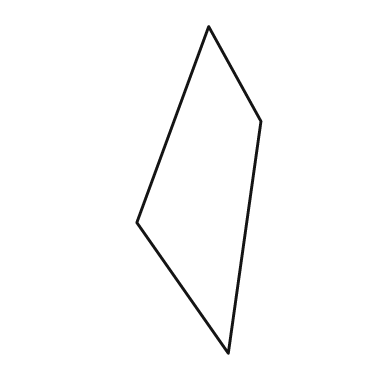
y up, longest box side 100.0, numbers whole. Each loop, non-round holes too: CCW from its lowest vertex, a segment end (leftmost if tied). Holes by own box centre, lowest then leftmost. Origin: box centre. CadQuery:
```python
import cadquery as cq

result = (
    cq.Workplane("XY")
    .moveTo(9.0, -50.0)
    .lineTo(19.0, 21.0)
    .lineTo(3.0, 50.0)
    .lineTo(-19.0, -10.0)
    .close()
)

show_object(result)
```